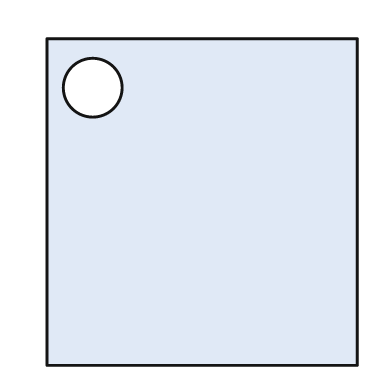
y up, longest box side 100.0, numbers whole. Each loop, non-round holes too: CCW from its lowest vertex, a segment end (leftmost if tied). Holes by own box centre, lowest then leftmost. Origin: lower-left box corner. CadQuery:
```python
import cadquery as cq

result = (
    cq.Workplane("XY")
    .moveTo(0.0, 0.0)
    .lineTo(95.0, 0.0)
    .lineTo(95.0, 100.0)
    .lineTo(0.0, 100.0)
    .close()
    .moveTo(14.0, 85.0)
    .circle(9.0)
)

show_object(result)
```